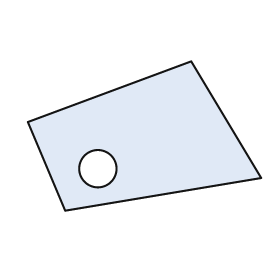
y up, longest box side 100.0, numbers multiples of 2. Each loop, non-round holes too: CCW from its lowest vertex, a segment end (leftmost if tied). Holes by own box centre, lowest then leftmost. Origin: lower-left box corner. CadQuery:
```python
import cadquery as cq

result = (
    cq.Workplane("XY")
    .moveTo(16.0, 0.0)
    .lineTo(100.0, 14.0)
    .lineTo(70.0, 64.0)
    .lineTo(0.0, 38.0)
    .close()
    .moveTo(30.0, 18.0)
    .circle(8.0)
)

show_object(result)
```